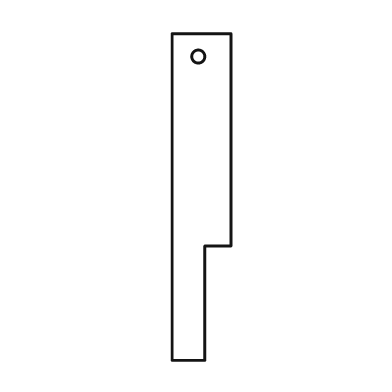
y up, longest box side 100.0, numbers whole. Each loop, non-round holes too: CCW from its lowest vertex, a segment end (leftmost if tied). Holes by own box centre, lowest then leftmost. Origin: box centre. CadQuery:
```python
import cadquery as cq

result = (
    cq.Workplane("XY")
    .moveTo(-9.0, -50.0)
    .lineTo(1.0, -50.0)
    .lineTo(1.0, -15.0)
    .lineTo(9.0, -15.0)
    .lineTo(9.0, 50.0)
    .lineTo(-9.0, 50.0)
    .close()
    .moveTo(-1.0, 43.0)
    .circle(2.0)
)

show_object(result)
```